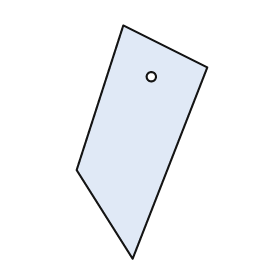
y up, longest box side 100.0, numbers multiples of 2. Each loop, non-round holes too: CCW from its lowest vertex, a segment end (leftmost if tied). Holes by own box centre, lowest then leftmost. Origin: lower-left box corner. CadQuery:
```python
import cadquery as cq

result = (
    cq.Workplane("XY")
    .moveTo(24.0, 0.0)
    .lineTo(56.0, 82.0)
    .lineTo(20.0, 100.0)
    .lineTo(0.0, 38.0)
    .close()
    .moveTo(32.0, 78.0)
    .circle(2.0)
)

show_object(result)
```